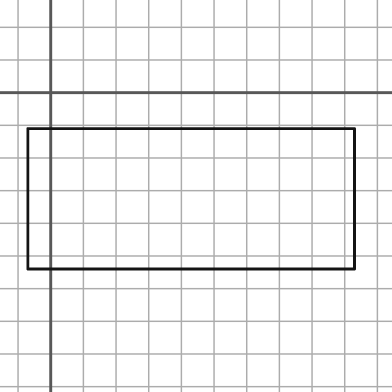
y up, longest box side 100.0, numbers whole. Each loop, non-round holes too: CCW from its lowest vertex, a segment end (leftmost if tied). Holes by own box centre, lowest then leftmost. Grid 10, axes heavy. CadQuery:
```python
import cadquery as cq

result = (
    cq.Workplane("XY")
    .moveTo(-7.0, -54.0)
    .lineTo(93.0, -54.0)
    .lineTo(93.0, -11.0)
    .lineTo(-7.0, -11.0)
    .close()
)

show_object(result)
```